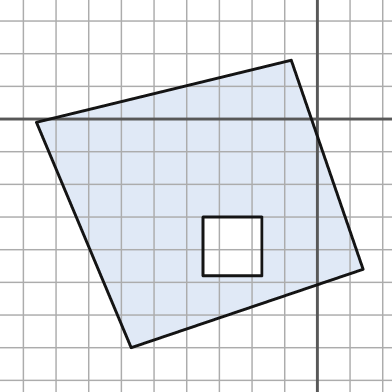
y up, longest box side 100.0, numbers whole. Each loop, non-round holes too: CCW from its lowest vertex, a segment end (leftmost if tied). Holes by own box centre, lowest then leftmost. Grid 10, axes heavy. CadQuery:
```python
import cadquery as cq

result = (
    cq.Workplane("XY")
    .moveTo(-57.0, -70.0)
    .lineTo(14.0, -46.0)
    .lineTo(-8.0, 18.0)
    .lineTo(-86.0, -1.0)
    .close()
    .moveTo(-35.0, -48.0)
    .lineTo(-17.0, -48.0)
    .lineTo(-17.0, -30.0)
    .lineTo(-35.0, -30.0)
    .close()
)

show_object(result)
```